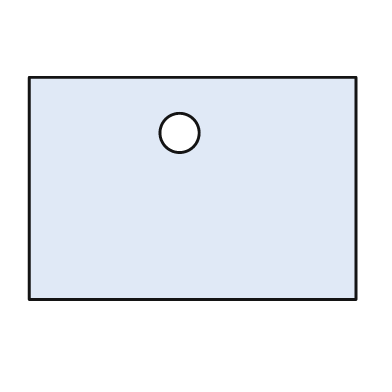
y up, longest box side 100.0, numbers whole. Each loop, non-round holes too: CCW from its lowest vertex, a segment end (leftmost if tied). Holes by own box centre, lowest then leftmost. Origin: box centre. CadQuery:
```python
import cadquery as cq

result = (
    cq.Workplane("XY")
    .moveTo(-50.0, -34.0)
    .lineTo(50.0, -34.0)
    .lineTo(50.0, 34.0)
    .lineTo(-50.0, 34.0)
    .close()
    .moveTo(-4.0, 17.0)
    .circle(6.0)
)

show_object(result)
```